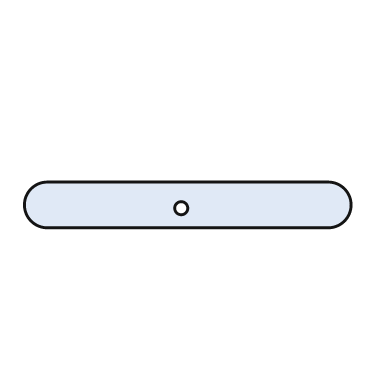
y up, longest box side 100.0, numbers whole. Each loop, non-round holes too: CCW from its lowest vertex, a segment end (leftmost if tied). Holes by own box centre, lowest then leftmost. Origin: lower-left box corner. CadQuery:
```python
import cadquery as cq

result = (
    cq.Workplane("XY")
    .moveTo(7.0, 0.0)
    .lineTo(93.0, 0.0)
    .threePointArc((100.0, 7.0), (93.0, 14.0))
    .lineTo(7.0, 14.0)
    .threePointArc((0.0, 7.0), (7.0, 0.0))
    .close()
    .moveTo(48.0, 6.0)
    .circle(2.0)
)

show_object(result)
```